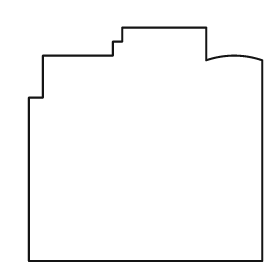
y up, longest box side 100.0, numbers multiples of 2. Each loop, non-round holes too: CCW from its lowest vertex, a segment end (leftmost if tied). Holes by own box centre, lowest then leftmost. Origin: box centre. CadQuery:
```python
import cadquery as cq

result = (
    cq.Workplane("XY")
    .moveTo(-50.0, -50.0)
    .lineTo(50.0, -50.0)
    .lineTo(50.0, 36.0)
    .threePointArc((38.0, 38.0), (26.0, 36.0))
    .lineTo(26.0, 50.0)
    .lineTo(-10.0, 50.0)
    .lineTo(-10.0, 44.0)
    .lineTo(-14.0, 44.0)
    .lineTo(-14.0, 38.0)
    .lineTo(-44.0, 38.0)
    .lineTo(-44.0, 20.0)
    .lineTo(-50.0, 20.0)
    .close()
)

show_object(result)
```